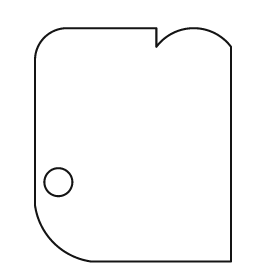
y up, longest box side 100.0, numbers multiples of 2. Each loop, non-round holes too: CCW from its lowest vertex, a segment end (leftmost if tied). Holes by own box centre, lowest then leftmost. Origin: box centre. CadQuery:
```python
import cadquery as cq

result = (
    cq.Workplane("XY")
    .moveTo(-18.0, -50.0)
    .lineTo(42.0, -50.0)
    .lineTo(42.0, 42.0)
    .threePointArc((26.0, 50.0), (10.0, 42.0))
    .lineTo(10.0, 50.0)
    .lineTo(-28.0, 50.0)
    .threePointArc((-38.0, 46.0), (-42.0, 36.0))
    .lineTo(-42.0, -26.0)
    .threePointArc((-34.0, -42.0), (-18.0, -50.0))
    .close()
    .moveTo(-32.0, -16.0)
    .circle(6.0)
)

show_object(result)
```